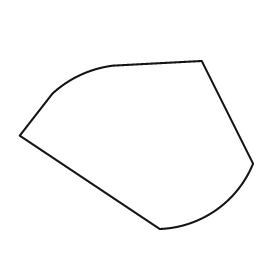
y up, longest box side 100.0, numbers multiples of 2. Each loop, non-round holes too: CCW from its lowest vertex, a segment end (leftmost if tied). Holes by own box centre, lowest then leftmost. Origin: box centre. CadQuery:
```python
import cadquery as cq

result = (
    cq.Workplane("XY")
    .moveTo(10.0, -36.0)
    .threePointArc((34.0, -28.0), (50.0, -8.0))
    .lineTo(28.0, 36.0)
    .lineTo(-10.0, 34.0)
    .threePointArc((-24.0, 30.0), (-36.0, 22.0))
    .lineTo(-50.0, 4.0)
    .close()
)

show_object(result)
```